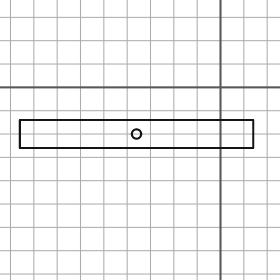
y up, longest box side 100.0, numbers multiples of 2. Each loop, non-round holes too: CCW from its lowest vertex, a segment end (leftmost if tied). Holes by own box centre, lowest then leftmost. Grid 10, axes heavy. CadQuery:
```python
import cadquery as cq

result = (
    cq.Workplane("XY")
    .moveTo(-86.0, -26.0)
    .lineTo(14.0, -26.0)
    .lineTo(14.0, -14.0)
    .lineTo(-86.0, -14.0)
    .close()
    .moveTo(-36.0, -20.0)
    .circle(2.0)
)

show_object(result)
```